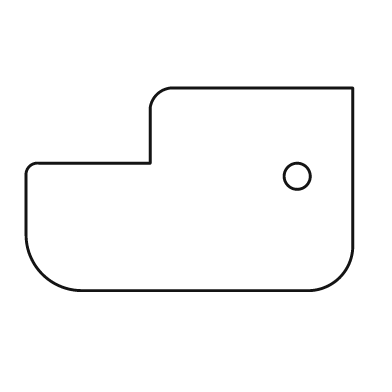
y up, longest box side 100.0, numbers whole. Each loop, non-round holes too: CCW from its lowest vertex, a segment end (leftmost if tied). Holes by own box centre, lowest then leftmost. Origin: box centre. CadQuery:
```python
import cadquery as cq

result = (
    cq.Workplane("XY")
    .moveTo(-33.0, -31.0)
    .lineTo(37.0, -31.0)
    .threePointArc((46.0, -27.0), (50.0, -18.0))
    .lineTo(50.0, 31.0)
    .lineTo(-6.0, 31.0)
    .threePointArc((-10.0, 29.0), (-12.0, 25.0))
    .lineTo(-12.0, 8.0)
    .lineTo(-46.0, 8.0)
    .threePointArc((-49.0, 7.0), (-50.0, 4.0))
    .lineTo(-50.0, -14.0)
    .threePointArc((-45.0, -26.0), (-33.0, -31.0))
    .close()
    .moveTo(33.0, 4.0)
    .circle(4.0)
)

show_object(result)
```